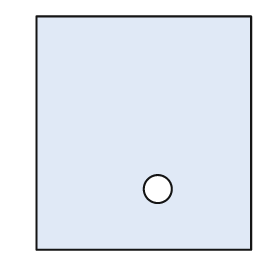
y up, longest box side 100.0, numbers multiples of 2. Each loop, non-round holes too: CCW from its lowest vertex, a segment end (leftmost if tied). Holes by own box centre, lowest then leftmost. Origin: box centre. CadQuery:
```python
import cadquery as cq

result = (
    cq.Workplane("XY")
    .moveTo(-46.0, -50.0)
    .lineTo(46.0, -50.0)
    .lineTo(46.0, 50.0)
    .lineTo(-46.0, 50.0)
    .close()
    .moveTo(6.0, -24.0)
    .circle(6.0)
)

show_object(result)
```